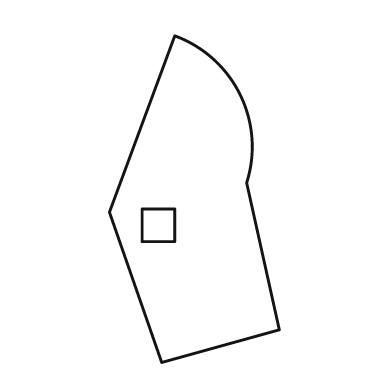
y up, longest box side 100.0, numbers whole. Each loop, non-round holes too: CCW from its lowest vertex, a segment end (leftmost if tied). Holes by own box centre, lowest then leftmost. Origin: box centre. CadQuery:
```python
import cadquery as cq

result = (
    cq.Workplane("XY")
    .moveTo(-10.0, -50.0)
    .lineTo(26.0, -40.0)
    .lineTo(16.0, 5.0)
    .threePointArc((14.0, 32.0), (-6.0, 50.0))
    .lineTo(-26.0, -4.0)
    .close()
    .moveTo(-16.0, -13.0)
    .lineTo(-6.0, -13.0)
    .lineTo(-6.0, -3.0)
    .lineTo(-16.0, -3.0)
    .close()
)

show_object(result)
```